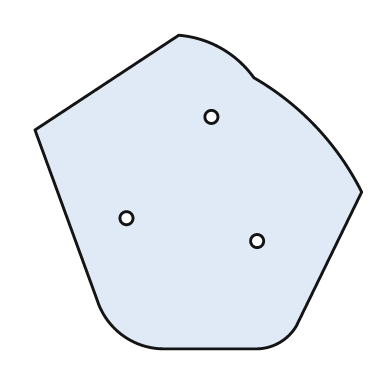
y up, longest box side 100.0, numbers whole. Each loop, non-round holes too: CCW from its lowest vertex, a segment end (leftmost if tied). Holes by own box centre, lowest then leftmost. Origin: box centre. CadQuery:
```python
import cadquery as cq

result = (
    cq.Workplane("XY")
    .moveTo(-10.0, -48.0)
    .lineTo(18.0, -48.0)
    .threePointArc((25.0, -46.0), (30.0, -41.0))
    .lineTo(50.0, 0.0)
    .threePointArc((36.0, 20.0), (17.0, 35.0))
    .threePointArc((7.0, 44.0), (-6.0, 48.0))
    .lineTo(-50.0, 19.0)
    .lineTo(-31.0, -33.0)
    .threePointArc((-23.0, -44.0), (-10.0, -48.0))
    .close()
    .moveTo(18.0, -15.0)
    .circle(2.0)
    .moveTo(-22.0, -8.0)
    .circle(2.0)
    .moveTo(4.0, 23.0)
    .circle(2.0)
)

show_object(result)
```